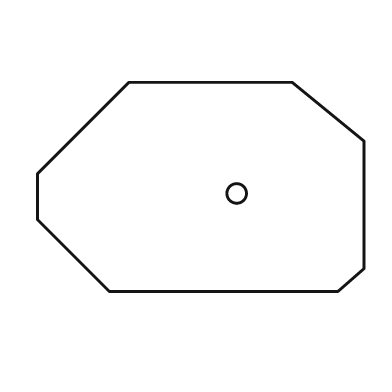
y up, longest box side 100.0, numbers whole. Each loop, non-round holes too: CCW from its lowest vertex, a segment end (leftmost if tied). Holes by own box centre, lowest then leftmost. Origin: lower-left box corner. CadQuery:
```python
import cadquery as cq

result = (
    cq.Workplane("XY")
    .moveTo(22.0, 0.0)
    .lineTo(92.0, 0.0)
    .lineTo(100.0, 7.0)
    .lineTo(100.0, 46.0)
    .lineTo(78.0, 64.0)
    .lineTo(28.0, 64.0)
    .lineTo(0.0, 36.0)
    .lineTo(0.0, 22.0)
    .close()
    .moveTo(61.0, 30.0)
    .circle(3.0)
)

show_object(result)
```